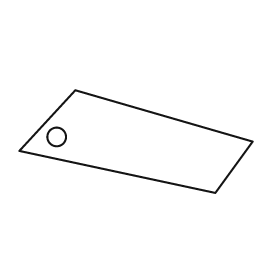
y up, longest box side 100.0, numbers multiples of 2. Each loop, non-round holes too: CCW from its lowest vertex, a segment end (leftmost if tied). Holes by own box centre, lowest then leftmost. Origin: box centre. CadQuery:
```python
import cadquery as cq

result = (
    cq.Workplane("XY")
    .moveTo(34.0, -22.0)
    .lineTo(50.0, 0.0)
    .lineTo(-26.0, 22.0)
    .lineTo(-50.0, -4.0)
    .close()
    .moveTo(-34.0, 2.0)
    .circle(4.0)
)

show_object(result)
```